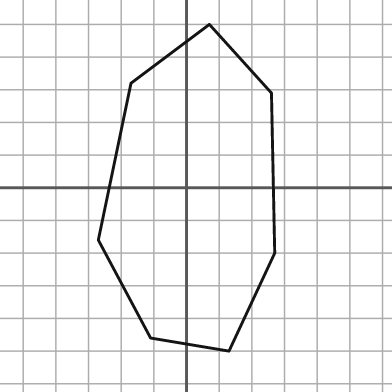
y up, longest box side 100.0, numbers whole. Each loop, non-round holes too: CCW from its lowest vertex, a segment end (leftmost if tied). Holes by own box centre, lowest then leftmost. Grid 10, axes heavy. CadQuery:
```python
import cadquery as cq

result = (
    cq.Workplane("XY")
    .moveTo(13.0, -50.0)
    .lineTo(27.0, -20.0)
    .lineTo(26.0, 29.0)
    .lineTo(7.0, 50.0)
    .lineTo(-17.0, 32.0)
    .lineTo(-27.0, -16.0)
    .lineTo(-11.0, -46.0)
    .close()
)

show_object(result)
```